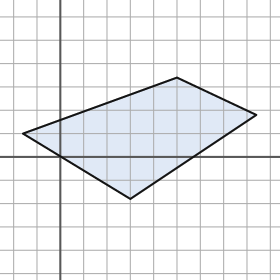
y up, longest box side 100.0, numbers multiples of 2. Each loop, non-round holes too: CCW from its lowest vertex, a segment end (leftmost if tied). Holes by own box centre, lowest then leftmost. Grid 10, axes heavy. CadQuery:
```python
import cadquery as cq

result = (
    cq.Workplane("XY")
    .moveTo(30.0, -18.0)
    .lineTo(84.0, 18.0)
    .lineTo(50.0, 34.0)
    .lineTo(-16.0, 10.0)
    .close()
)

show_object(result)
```